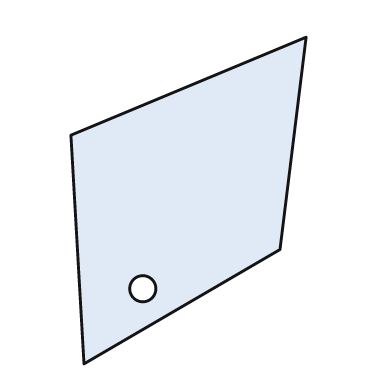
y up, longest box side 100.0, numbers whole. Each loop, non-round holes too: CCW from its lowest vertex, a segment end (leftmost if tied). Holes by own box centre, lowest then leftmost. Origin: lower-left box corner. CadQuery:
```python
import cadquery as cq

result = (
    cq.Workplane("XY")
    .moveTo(4.0, 0.0)
    .lineTo(64.0, 35.0)
    .lineTo(72.0, 100.0)
    .lineTo(0.0, 70.0)
    .close()
    .moveTo(22.0, 23.0)
    .circle(4.0)
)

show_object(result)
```